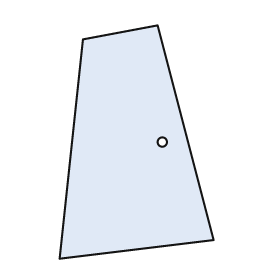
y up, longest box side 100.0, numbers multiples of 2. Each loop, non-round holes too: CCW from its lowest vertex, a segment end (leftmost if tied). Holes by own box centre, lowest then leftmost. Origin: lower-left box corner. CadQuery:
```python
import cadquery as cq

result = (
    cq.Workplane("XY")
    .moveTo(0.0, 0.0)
    .lineTo(66.0, 8.0)
    .lineTo(42.0, 100.0)
    .lineTo(10.0, 94.0)
    .close()
    .moveTo(44.0, 50.0)
    .circle(2.0)
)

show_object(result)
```